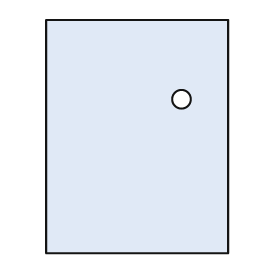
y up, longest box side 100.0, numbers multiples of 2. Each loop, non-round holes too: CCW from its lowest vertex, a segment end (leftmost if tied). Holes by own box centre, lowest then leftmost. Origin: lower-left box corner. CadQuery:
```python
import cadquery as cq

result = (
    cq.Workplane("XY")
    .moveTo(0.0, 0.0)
    .lineTo(78.0, 0.0)
    .lineTo(78.0, 100.0)
    .lineTo(0.0, 100.0)
    .close()
    .moveTo(58.0, 66.0)
    .circle(4.0)
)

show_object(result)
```